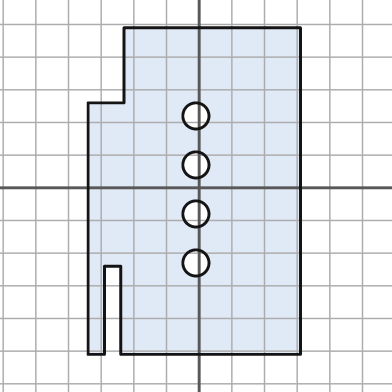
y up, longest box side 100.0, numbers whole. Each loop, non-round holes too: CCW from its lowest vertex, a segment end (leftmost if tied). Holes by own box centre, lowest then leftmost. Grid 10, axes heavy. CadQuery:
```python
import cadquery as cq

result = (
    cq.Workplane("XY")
    .moveTo(-34.0, -51.0)
    .lineTo(-29.0, -51.0)
    .lineTo(-29.0, -24.0)
    .lineTo(-24.0, -24.0)
    .lineTo(-24.0, -51.0)
    .lineTo(31.0, -51.0)
    .lineTo(31.0, 49.0)
    .lineTo(-23.0, 49.0)
    .lineTo(-23.0, 26.0)
    .lineTo(-34.0, 26.0)
    .close()
    .moveTo(-1.0, -23.0)
    .circle(4.0)
    .moveTo(-1.0, -8.0)
    .circle(4.0)
    .moveTo(-1.0, 7.0)
    .circle(4.0)
    .moveTo(-1.0, 22.0)
    .circle(4.0)
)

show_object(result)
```